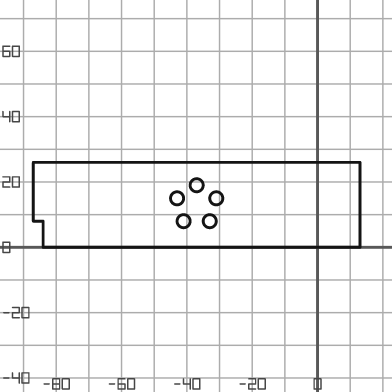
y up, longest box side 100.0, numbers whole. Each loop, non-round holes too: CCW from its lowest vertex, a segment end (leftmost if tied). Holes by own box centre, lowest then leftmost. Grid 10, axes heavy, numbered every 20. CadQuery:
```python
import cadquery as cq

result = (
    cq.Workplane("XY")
    .moveTo(-84.0, 0.0)
    .lineTo(13.0, 0.0)
    .lineTo(13.0, 26.0)
    .lineTo(-87.0, 26.0)
    .lineTo(-87.0, 8.0)
    .lineTo(-84.0, 8.0)
    .close()
    .moveTo(-41.0, 8.0)
    .circle(2.0)
    .moveTo(-33.0, 8.0)
    .circle(2.0)
    .moveTo(-43.0, 15.0)
    .circle(2.0)
    .moveTo(-31.0, 15.0)
    .circle(2.0)
    .moveTo(-37.0, 19.0)
    .circle(2.0)
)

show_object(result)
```